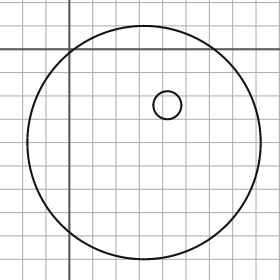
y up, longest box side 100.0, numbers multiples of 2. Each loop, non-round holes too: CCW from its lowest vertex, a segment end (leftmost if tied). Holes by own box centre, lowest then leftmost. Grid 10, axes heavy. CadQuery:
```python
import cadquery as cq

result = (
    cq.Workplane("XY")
    .moveTo(32.0, -40.0)
    .circle(50.0)
    .moveTo(42.0, -24.0)
    .circle(6.0)
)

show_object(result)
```